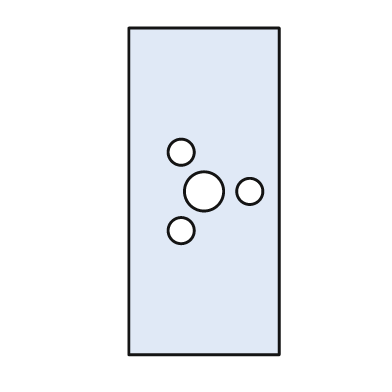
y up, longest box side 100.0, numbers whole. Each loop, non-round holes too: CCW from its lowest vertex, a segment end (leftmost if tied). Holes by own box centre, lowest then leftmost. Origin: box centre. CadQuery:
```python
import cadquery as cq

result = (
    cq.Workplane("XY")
    .moveTo(-23.0, -50.0)
    .lineTo(23.0, -50.0)
    .lineTo(23.0, 50.0)
    .lineTo(-23.0, 50.0)
    .close()
    .moveTo(-7.0, -12.0)
    .circle(4.0)
    .moveTo(0.0, 0.0)
    .circle(6.0)
    .moveTo(14.0, 0.0)
    .circle(4.0)
    .moveTo(-7.0, 12.0)
    .circle(4.0)
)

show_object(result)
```